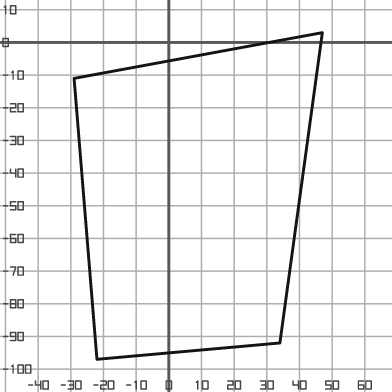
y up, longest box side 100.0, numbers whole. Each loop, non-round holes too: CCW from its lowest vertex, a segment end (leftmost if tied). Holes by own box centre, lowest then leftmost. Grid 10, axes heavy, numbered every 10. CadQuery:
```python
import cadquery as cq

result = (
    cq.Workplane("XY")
    .moveTo(-22.0, -97.0)
    .lineTo(34.0, -92.0)
    .lineTo(47.0, 3.0)
    .lineTo(-29.0, -11.0)
    .close()
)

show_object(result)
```